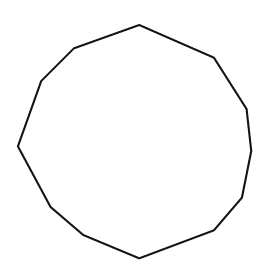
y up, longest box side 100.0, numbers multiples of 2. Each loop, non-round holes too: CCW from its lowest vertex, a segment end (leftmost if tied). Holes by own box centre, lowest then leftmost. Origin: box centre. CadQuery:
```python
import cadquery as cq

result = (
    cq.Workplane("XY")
    .moveTo(2.0, -50.0)
    .lineTo(34.0, -38.0)
    .lineTo(46.0, -24.0)
    .lineTo(50.0, -4.0)
    .lineTo(48.0, 14.0)
    .lineTo(34.0, 36.0)
    .lineTo(2.0, 50.0)
    .lineTo(-26.0, 40.0)
    .lineTo(-40.0, 26.0)
    .lineTo(-50.0, -2.0)
    .lineTo(-36.0, -28.0)
    .lineTo(-22.0, -40.0)
    .close()
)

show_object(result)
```